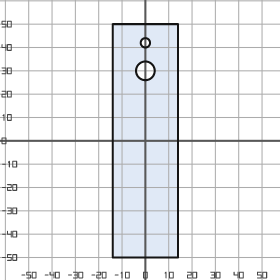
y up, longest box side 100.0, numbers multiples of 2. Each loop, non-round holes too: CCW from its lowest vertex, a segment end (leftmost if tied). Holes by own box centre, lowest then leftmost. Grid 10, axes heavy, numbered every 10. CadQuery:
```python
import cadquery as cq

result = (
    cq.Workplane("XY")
    .moveTo(-14.0, -50.0)
    .lineTo(14.0, -50.0)
    .lineTo(14.0, 50.0)
    .lineTo(-14.0, 50.0)
    .close()
    .moveTo(0.0, 30.0)
    .circle(4.0)
    .moveTo(0.0, 42.0)
    .circle(2.0)
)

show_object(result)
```